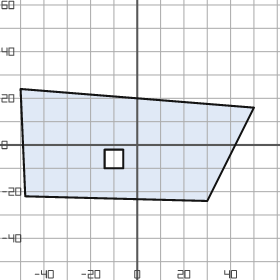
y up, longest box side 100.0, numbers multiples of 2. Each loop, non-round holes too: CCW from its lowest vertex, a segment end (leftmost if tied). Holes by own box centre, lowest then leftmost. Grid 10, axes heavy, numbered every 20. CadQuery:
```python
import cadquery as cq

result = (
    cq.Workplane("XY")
    .moveTo(30.0, -24.0)
    .lineTo(50.0, 16.0)
    .lineTo(-50.0, 24.0)
    .lineTo(-48.0, -22.0)
    .close()
    .moveTo(-14.0, -10.0)
    .lineTo(-6.0, -10.0)
    .lineTo(-6.0, -2.0)
    .lineTo(-14.0, -2.0)
    .close()
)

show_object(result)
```